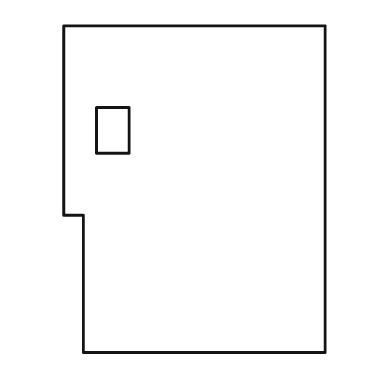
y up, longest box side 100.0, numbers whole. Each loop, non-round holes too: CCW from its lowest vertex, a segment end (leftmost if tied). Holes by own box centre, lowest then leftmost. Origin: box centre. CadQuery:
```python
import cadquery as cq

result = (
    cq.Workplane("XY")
    .moveTo(-34.0, -50.0)
    .lineTo(40.0, -50.0)
    .lineTo(40.0, 50.0)
    .lineTo(-40.0, 50.0)
    .lineTo(-40.0, -8.0)
    .lineTo(-34.0, -8.0)
    .close()
    .moveTo(-30.0, 11.0)
    .lineTo(-20.0, 11.0)
    .lineTo(-20.0, 25.0)
    .lineTo(-30.0, 25.0)
    .close()
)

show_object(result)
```